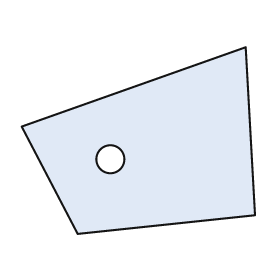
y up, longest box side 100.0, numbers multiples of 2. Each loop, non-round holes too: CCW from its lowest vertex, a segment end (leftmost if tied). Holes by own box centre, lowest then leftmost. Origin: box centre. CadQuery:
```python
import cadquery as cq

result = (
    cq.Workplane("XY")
    .moveTo(-26.0, -40.0)
    .lineTo(50.0, -32.0)
    .lineTo(46.0, 40.0)
    .lineTo(-50.0, 6.0)
    .close()
    .moveTo(-12.0, -8.0)
    .circle(6.0)
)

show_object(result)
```